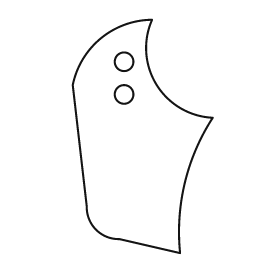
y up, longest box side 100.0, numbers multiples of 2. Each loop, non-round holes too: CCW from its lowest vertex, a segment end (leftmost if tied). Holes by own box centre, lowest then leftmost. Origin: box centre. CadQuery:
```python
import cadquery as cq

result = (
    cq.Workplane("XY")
    .moveTo(16.0, -50.0)
    .threePointArc((18.0, -20.0), (30.0, 8.0))
    .threePointArc((6.0, 22.0), (4.0, 50.0))
    .threePointArc((-18.0, 42.0), (-30.0, 22.0))
    .lineTo(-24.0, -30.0)
    .threePointArc((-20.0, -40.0), (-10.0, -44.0))
    .close()
    .moveTo(-8.0, 18.0)
    .circle(4.0)
    .moveTo(-8.0, 32.0)
    .circle(4.0)
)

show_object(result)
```